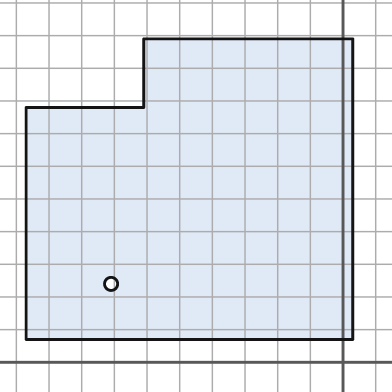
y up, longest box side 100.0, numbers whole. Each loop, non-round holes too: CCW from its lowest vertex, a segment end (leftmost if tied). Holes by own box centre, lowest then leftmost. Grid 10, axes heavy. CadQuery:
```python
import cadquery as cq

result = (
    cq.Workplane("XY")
    .moveTo(-97.0, 7.0)
    .lineTo(3.0, 7.0)
    .lineTo(3.0, 99.0)
    .lineTo(-61.0, 99.0)
    .lineTo(-61.0, 78.0)
    .lineTo(-97.0, 78.0)
    .close()
    .moveTo(-71.0, 24.0)
    .circle(2.0)
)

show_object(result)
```